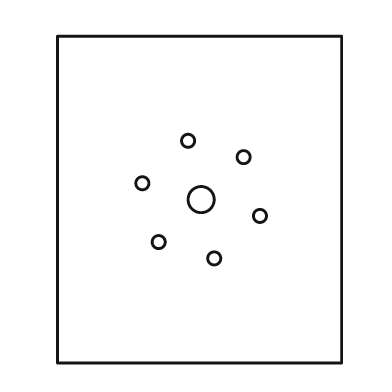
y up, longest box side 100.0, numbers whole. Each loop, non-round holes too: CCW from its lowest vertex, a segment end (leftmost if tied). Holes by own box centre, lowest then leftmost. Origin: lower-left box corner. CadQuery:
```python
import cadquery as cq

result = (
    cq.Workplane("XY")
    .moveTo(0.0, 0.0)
    .lineTo(87.0, 0.0)
    .lineTo(87.0, 100.0)
    .lineTo(0.0, 100.0)
    .close()
    .moveTo(48.0, 32.0)
    .circle(2.0)
    .moveTo(31.0, 37.0)
    .circle(2.0)
    .moveTo(62.0, 45.0)
    .circle(2.0)
    .moveTo(44.0, 50.0)
    .circle(4.0)
    .moveTo(26.0, 55.0)
    .circle(2.0)
    .moveTo(57.0, 63.0)
    .circle(2.0)
    .moveTo(40.0, 68.0)
    .circle(2.0)
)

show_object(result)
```